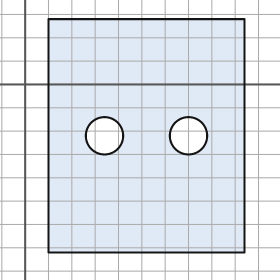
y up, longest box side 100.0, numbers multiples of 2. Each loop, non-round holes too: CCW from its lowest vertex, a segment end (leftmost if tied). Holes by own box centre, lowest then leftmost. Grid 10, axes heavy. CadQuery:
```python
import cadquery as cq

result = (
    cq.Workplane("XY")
    .moveTo(10.0, -72.0)
    .lineTo(94.0, -72.0)
    .lineTo(94.0, 28.0)
    .lineTo(10.0, 28.0)
    .close()
    .moveTo(34.0, -22.0)
    .circle(8.0)
    .moveTo(70.0, -22.0)
    .circle(8.0)
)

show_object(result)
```